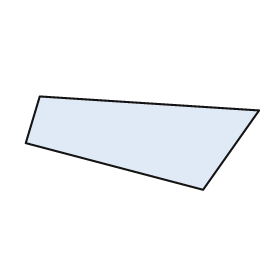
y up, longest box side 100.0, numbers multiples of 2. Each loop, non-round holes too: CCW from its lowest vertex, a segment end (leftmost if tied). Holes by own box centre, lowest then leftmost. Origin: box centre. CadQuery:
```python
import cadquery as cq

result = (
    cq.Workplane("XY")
    .moveTo(26.0, -20.0)
    .lineTo(50.0, 14.0)
    .lineTo(-44.0, 20.0)
    .lineTo(-50.0, 0.0)
    .close()
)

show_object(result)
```